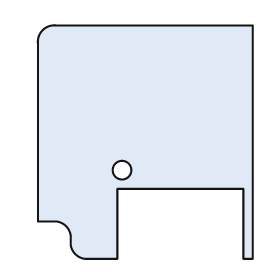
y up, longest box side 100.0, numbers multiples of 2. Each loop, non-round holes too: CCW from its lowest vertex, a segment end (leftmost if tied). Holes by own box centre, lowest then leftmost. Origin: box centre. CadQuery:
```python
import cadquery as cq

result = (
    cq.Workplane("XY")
    .moveTo(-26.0, -50.0)
    .lineTo(-12.0, -50.0)
    .lineTo(-12.0, -20.0)
    .lineTo(42.0, -20.0)
    .lineTo(42.0, -50.0)
    .lineTo(46.0, -50.0)
    .lineTo(46.0, 50.0)
    .lineTo(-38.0, 50.0)
    .threePointArc((-44.0, 48.0), (-46.0, 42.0))
    .lineTo(-46.0, -34.0)
    .lineTo(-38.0, -34.0)
    .threePointArc((-34.0, -36.0), (-32.0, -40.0))
    .lineTo(-32.0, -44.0)
    .threePointArc((-30.0, -48.0), (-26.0, -50.0))
    .close()
    .moveTo(-10.0, -12.0)
    .circle(4.0)
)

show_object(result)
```